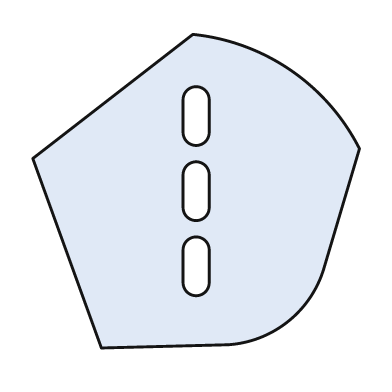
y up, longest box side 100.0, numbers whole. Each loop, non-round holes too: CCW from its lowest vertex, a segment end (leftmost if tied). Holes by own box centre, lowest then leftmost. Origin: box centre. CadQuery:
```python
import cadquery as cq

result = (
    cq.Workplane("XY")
    .moveTo(-29.0, -48.0)
    .lineTo(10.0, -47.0)
    .threePointArc((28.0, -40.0), (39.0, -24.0))
    .lineTo(50.0, 13.0)
    .threePointArc((29.0, 37.0), (-1.0, 48.0))
    .lineTo(-50.0, 10.0)
    .close()
    .moveTo(-4.0, -28.0)
    .threePointArc((0.0, -32.0), (4.0, -28.0))
    .lineTo(4.0, -18.0)
    .threePointArc((0.0, -14.0), (-4.0, -18.0))
    .close()
    .moveTo(-4.0, -5.0)
    .threePointArc((0.0, -9.0), (4.0, -5.0))
    .lineTo(4.0, 5.0)
    .threePointArc((0.0, 9.0), (-4.0, 5.0))
    .close()
    .moveTo(-4.0, 18.0)
    .threePointArc((0.0, 14.0), (4.0, 18.0))
    .lineTo(4.0, 28.0)
    .threePointArc((0.0, 32.0), (-4.0, 28.0))
    .close()
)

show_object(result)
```